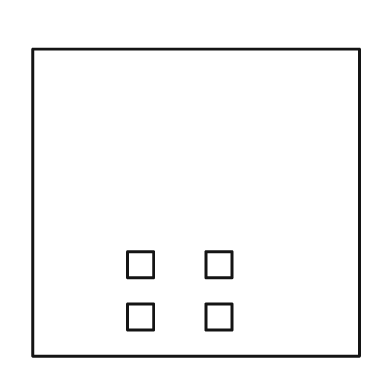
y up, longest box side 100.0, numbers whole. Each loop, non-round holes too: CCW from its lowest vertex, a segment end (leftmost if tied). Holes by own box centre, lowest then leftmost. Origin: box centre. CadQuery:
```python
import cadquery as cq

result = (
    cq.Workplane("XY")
    .moveTo(-50.0, -47.0)
    .lineTo(50.0, -47.0)
    .lineTo(50.0, 47.0)
    .lineTo(-50.0, 47.0)
    .close()
    .moveTo(-21.0, -39.0)
    .lineTo(-13.0, -39.0)
    .lineTo(-13.0, -31.0)
    .lineTo(-21.0, -31.0)
    .close()
    .moveTo(3.0, -39.0)
    .lineTo(11.0, -39.0)
    .lineTo(11.0, -31.0)
    .lineTo(3.0, -31.0)
    .close()
    .moveTo(-21.0, -23.0)
    .lineTo(-13.0, -23.0)
    .lineTo(-13.0, -15.0)
    .lineTo(-21.0, -15.0)
    .close()
    .moveTo(3.0, -23.0)
    .lineTo(11.0, -23.0)
    .lineTo(11.0, -15.0)
    .lineTo(3.0, -15.0)
    .close()
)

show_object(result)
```